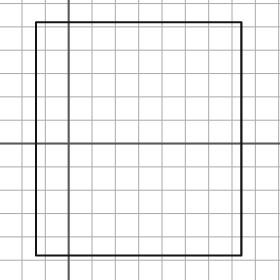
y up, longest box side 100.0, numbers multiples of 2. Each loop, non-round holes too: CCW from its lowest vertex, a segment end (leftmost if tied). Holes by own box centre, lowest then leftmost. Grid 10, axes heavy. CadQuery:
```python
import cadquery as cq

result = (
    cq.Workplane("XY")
    .moveTo(-14.0, -48.0)
    .lineTo(74.0, -48.0)
    .lineTo(74.0, 52.0)
    .lineTo(-14.0, 52.0)
    .close()
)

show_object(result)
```